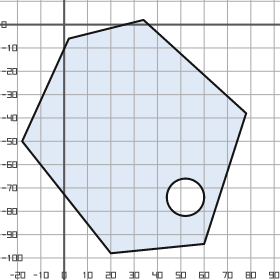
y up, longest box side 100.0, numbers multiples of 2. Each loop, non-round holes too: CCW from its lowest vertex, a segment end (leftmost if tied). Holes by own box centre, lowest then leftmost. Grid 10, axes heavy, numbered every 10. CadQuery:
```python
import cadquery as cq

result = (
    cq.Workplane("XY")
    .moveTo(20.0, -98.0)
    .lineTo(60.0, -94.0)
    .lineTo(78.0, -38.0)
    .lineTo(34.0, 2.0)
    .lineTo(2.0, -6.0)
    .lineTo(-18.0, -50.0)
    .close()
    .moveTo(52.0, -74.0)
    .circle(8.0)
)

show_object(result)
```